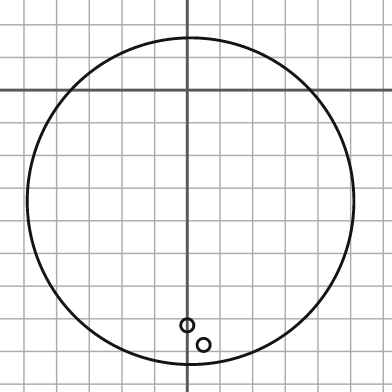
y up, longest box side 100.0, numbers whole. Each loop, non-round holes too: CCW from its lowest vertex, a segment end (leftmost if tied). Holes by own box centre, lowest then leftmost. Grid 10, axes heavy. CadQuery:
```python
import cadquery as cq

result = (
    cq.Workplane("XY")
    .moveTo(1.0, -34.0)
    .circle(50.0)
    .moveTo(5.0, -78.0)
    .circle(2.0)
    .moveTo(0.0, -72.0)
    .circle(2.0)
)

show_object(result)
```